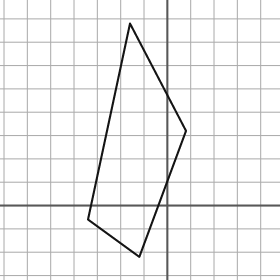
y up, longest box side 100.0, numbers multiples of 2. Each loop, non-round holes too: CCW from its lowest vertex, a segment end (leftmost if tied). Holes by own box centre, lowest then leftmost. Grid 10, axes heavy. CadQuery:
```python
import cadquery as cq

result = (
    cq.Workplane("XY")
    .moveTo(-12.0, -22.0)
    .lineTo(8.0, 32.0)
    .lineTo(-16.0, 78.0)
    .lineTo(-34.0, -6.0)
    .close()
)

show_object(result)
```